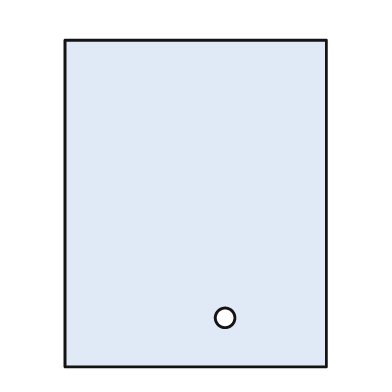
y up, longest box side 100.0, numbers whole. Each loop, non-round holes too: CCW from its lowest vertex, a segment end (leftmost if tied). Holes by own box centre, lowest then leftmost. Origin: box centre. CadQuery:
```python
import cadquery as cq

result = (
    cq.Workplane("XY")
    .moveTo(-40.0, -50.0)
    .lineTo(40.0, -50.0)
    .lineTo(40.0, 50.0)
    .lineTo(-40.0, 50.0)
    .close()
    .moveTo(9.0, -35.0)
    .circle(3.0)
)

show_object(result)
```